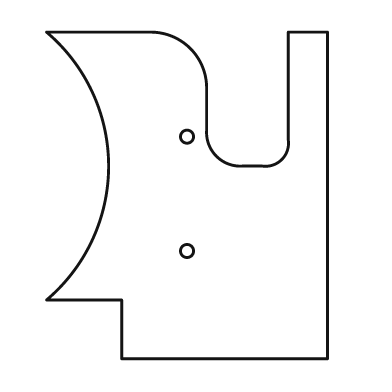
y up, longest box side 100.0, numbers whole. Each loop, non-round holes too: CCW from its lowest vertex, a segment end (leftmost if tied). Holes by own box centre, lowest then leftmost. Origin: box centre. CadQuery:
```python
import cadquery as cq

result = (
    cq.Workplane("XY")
    .moveTo(-20.0, -50.0)
    .lineTo(43.0, -50.0)
    .lineTo(43.0, 50.0)
    .lineTo(31.0, 50.0)
    .lineTo(31.0, 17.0)
    .threePointArc((29.0, 11.0), (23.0, 9.0))
    .lineTo(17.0, 9.0)
    .threePointArc((9.0, 12.0), (6.0, 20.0))
    .lineTo(6.0, 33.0)
    .threePointArc((1.0, 45.0), (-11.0, 50.0))
    .lineTo(-43.0, 50.0)
    .threePointArc((-24.0, 9.0), (-43.0, -32.0))
    .lineTo(-20.0, -32.0)
    .close()
    .moveTo(0.0, -17.0)
    .circle(2.0)
    .moveTo(0.0, 18.0)
    .circle(2.0)
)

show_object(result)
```